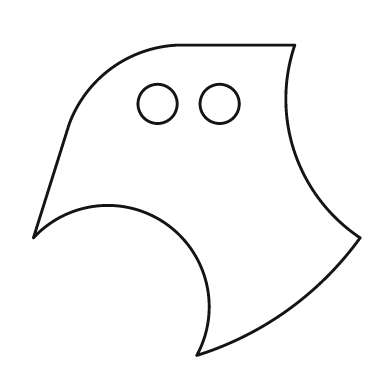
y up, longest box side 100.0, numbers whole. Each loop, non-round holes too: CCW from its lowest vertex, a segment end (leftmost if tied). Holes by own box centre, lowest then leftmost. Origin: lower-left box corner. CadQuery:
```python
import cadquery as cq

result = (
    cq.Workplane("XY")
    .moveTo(50.0, 0.0)
    .threePointArc((78.0, 14.0), (100.0, 36.0))
    .threePointArc((80.0, 62.0), (80.0, 95.0))
    .lineTo(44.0, 95.0)
    .threePointArc((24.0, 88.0), (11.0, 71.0))
    .lineTo(0.0, 36.0)
    .threePointArc((41.0, 40.0), (50.0, 0.0))
    .close()
    .moveTo(38.0, 77.0)
    .circle(6.0)
    .moveTo(57.0, 77.0)
    .circle(6.0)
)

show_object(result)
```